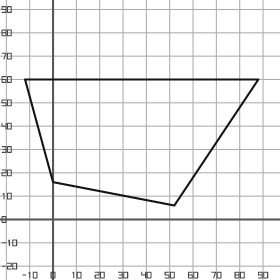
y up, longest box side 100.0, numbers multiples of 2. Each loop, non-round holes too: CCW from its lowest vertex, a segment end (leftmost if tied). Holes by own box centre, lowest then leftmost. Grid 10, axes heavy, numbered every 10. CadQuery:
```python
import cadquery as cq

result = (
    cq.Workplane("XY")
    .moveTo(52.0, 6.0)
    .lineTo(88.0, 60.0)
    .lineTo(-12.0, 60.0)
    .lineTo(0.0, 16.0)
    .close()
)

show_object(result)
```